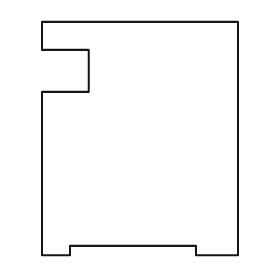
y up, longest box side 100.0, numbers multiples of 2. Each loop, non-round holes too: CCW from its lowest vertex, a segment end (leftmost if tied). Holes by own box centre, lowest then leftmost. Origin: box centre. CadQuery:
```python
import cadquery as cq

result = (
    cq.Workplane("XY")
    .moveTo(-42.0, -50.0)
    .lineTo(-30.0, -50.0)
    .lineTo(-30.0, -46.0)
    .lineTo(24.0, -46.0)
    .lineTo(24.0, -50.0)
    .lineTo(42.0, -50.0)
    .lineTo(42.0, 50.0)
    .lineTo(-42.0, 50.0)
    .lineTo(-42.0, 38.0)
    .lineTo(-22.0, 38.0)
    .lineTo(-22.0, 20.0)
    .lineTo(-42.0, 20.0)
    .close()
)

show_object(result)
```